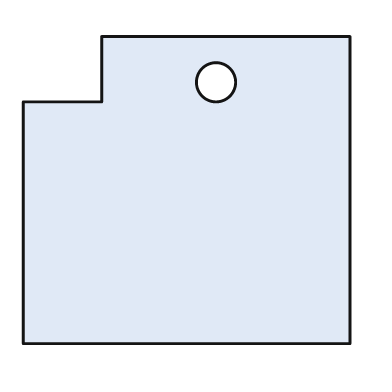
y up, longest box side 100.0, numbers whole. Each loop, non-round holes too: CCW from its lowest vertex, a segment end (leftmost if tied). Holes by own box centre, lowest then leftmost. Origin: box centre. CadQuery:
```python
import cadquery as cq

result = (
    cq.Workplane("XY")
    .moveTo(-50.0, -47.0)
    .lineTo(50.0, -47.0)
    .lineTo(50.0, 47.0)
    .lineTo(-26.0, 47.0)
    .lineTo(-26.0, 27.0)
    .lineTo(-50.0, 27.0)
    .close()
    .moveTo(9.0, 33.0)
    .circle(6.0)
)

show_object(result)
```